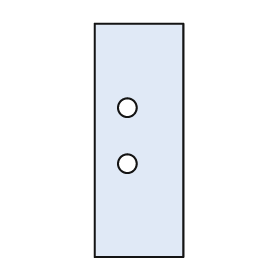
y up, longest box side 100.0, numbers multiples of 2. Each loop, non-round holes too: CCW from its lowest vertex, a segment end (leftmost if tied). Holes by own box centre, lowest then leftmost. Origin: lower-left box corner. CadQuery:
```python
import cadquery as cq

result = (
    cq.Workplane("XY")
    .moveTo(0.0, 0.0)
    .lineTo(38.0, 0.0)
    .lineTo(38.0, 100.0)
    .lineTo(0.0, 100.0)
    .close()
    .moveTo(14.0, 40.0)
    .circle(4.0)
    .moveTo(14.0, 64.0)
    .circle(4.0)
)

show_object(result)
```